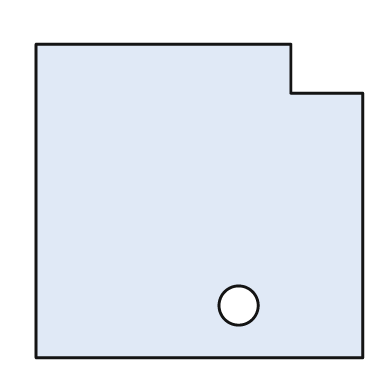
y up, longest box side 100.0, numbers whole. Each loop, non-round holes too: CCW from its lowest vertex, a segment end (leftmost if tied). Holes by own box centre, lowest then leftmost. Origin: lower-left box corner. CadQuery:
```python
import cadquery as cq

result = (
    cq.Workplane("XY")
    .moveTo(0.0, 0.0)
    .lineTo(100.0, 0.0)
    .lineTo(100.0, 81.0)
    .lineTo(78.0, 81.0)
    .lineTo(78.0, 96.0)
    .lineTo(0.0, 96.0)
    .close()
    .moveTo(62.0, 16.0)
    .circle(6.0)
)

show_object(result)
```